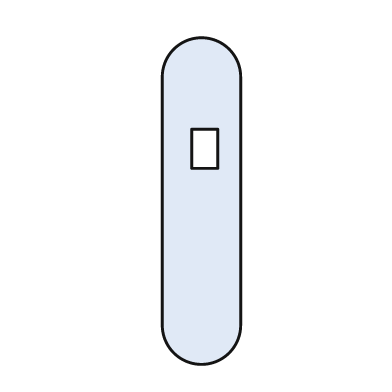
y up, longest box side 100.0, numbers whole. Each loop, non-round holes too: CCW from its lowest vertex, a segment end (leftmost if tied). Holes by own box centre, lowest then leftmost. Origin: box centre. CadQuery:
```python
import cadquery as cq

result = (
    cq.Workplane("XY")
    .moveTo(-12.0, -38.0)
    .threePointArc((0.0, -50.0), (12.0, -38.0))
    .lineTo(12.0, 38.0)
    .threePointArc((0.0, 50.0), (-12.0, 38.0))
    .close()
    .moveTo(-3.0, 10.0)
    .lineTo(5.0, 10.0)
    .lineTo(5.0, 22.0)
    .lineTo(-3.0, 22.0)
    .close()
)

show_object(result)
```